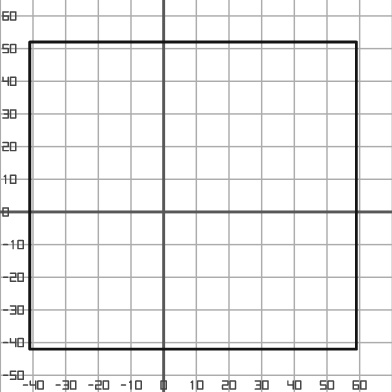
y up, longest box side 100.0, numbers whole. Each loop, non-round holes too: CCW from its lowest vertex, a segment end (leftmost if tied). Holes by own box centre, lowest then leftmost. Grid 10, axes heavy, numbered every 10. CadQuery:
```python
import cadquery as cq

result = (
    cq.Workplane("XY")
    .moveTo(-41.0, -42.0)
    .lineTo(59.0, -42.0)
    .lineTo(59.0, 52.0)
    .lineTo(-41.0, 52.0)
    .close()
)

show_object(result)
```